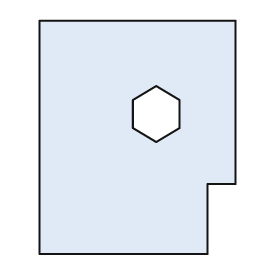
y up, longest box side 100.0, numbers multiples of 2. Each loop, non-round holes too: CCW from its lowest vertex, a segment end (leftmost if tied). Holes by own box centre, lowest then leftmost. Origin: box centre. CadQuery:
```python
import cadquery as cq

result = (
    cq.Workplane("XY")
    .moveTo(-42.0, -50.0)
    .lineTo(30.0, -50.0)
    .lineTo(30.0, -20.0)
    .lineTo(42.0, -20.0)
    .lineTo(42.0, 50.0)
    .lineTo(-42.0, 50.0)
    .close()
    .moveTo(8.0, -2.0)
    .lineTo(18.0, 4.0)
    .lineTo(18.0, 16.0)
    .lineTo(8.0, 22.0)
    .lineTo(-2.0, 16.0)
    .lineTo(-2.0, 4.0)
    .close()
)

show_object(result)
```